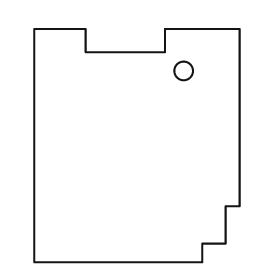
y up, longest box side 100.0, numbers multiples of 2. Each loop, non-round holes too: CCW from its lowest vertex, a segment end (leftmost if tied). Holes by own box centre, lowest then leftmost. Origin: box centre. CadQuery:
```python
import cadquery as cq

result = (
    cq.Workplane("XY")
    .moveTo(-44.0, -50.0)
    .lineTo(28.0, -50.0)
    .lineTo(28.0, -42.0)
    .lineTo(38.0, -42.0)
    .lineTo(38.0, -26.0)
    .lineTo(44.0, -26.0)
    .lineTo(44.0, 50.0)
    .lineTo(12.0, 50.0)
    .lineTo(12.0, 40.0)
    .lineTo(-22.0, 40.0)
    .lineTo(-22.0, 50.0)
    .lineTo(-44.0, 50.0)
    .close()
    .moveTo(20.0, 32.0)
    .circle(4.0)
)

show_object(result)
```